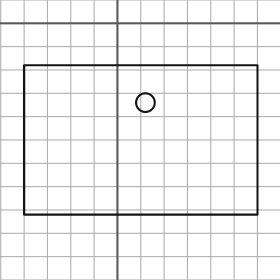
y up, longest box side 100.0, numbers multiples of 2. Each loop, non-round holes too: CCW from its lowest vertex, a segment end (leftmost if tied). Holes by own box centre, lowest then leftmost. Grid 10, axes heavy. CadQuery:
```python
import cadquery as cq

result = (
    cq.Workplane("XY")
    .moveTo(-40.0, -82.0)
    .lineTo(60.0, -82.0)
    .lineTo(60.0, -18.0)
    .lineTo(-40.0, -18.0)
    .close()
    .moveTo(12.0, -34.0)
    .circle(4.0)
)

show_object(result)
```